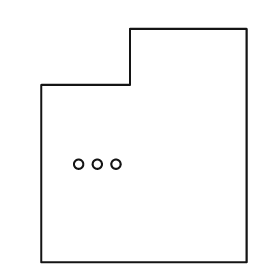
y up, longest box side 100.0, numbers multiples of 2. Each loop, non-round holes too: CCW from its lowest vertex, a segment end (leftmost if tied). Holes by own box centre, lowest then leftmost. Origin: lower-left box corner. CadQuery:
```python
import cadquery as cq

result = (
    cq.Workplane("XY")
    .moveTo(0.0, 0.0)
    .lineTo(88.0, 0.0)
    .lineTo(88.0, 100.0)
    .lineTo(38.0, 100.0)
    .lineTo(38.0, 76.0)
    .lineTo(0.0, 76.0)
    .close()
    .moveTo(16.0, 42.0)
    .circle(2.0)
    .moveTo(24.0, 42.0)
    .circle(2.0)
    .moveTo(32.0, 42.0)
    .circle(2.0)
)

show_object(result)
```